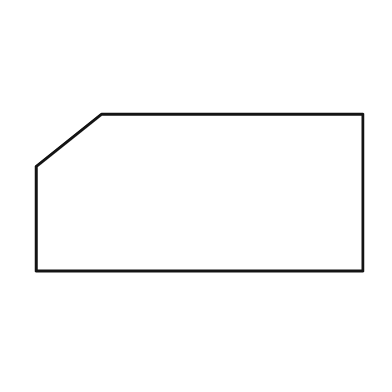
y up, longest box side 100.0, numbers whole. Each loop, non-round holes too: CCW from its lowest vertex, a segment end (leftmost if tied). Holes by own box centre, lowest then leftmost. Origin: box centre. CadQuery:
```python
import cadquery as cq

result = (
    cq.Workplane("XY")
    .moveTo(-50.0, -24.0)
    .lineTo(50.0, -24.0)
    .lineTo(50.0, 24.0)
    .lineTo(-30.0, 24.0)
    .lineTo(-50.0, 8.0)
    .close()
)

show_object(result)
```